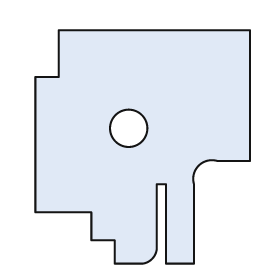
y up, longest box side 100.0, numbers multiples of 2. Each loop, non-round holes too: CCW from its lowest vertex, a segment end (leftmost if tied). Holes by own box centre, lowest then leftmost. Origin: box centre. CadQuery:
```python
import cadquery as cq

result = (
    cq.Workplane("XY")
    .moveTo(-12.0, -50.0)
    .lineTo(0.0, -50.0)
    .threePointArc((4.0, -48.0), (6.0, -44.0))
    .lineTo(6.0, -16.0)
    .lineTo(10.0, -16.0)
    .lineTo(10.0, -50.0)
    .lineTo(22.0, -50.0)
    .lineTo(22.0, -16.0)
    .threePointArc((24.0, -8.0), (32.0, -6.0))
    .lineTo(46.0, -6.0)
    .lineTo(46.0, 50.0)
    .lineTo(-36.0, 50.0)
    .lineTo(-36.0, 30.0)
    .lineTo(-46.0, 30.0)
    .lineTo(-46.0, -28.0)
    .lineTo(-22.0, -28.0)
    .lineTo(-22.0, -40.0)
    .lineTo(-12.0, -40.0)
    .close()
    .moveTo(-6.0, 8.0)
    .circle(8.0)
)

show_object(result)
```